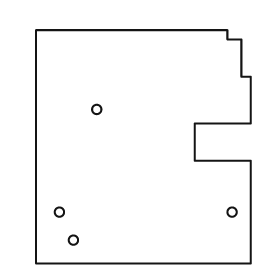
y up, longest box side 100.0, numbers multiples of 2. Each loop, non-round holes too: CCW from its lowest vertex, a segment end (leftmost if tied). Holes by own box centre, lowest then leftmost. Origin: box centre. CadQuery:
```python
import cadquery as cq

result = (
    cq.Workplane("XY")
    .moveTo(-46.0, -50.0)
    .lineTo(46.0, -50.0)
    .lineTo(46.0, -6.0)
    .lineTo(22.0, -6.0)
    .lineTo(22.0, 10.0)
    .lineTo(46.0, 10.0)
    .lineTo(46.0, 30.0)
    .lineTo(42.0, 30.0)
    .lineTo(42.0, 46.0)
    .lineTo(36.0, 46.0)
    .lineTo(36.0, 50.0)
    .lineTo(-46.0, 50.0)
    .close()
    .moveTo(-30.0, -40.0)
    .circle(2.0)
    .moveTo(-36.0, -28.0)
    .circle(2.0)
    .moveTo(38.0, -28.0)
    .circle(2.0)
    .moveTo(-20.0, 16.0)
    .circle(2.0)
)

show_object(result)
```